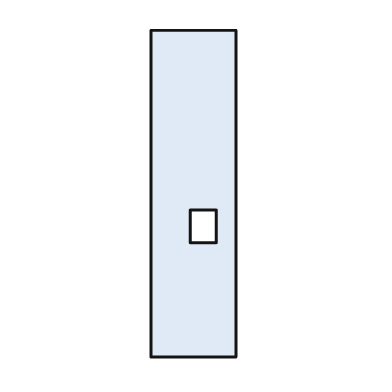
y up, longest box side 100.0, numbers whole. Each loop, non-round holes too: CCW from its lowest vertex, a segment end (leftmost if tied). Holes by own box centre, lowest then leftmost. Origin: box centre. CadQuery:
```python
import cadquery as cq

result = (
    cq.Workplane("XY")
    .moveTo(-13.0, -50.0)
    .lineTo(13.0, -50.0)
    .lineTo(13.0, 50.0)
    .lineTo(-13.0, 50.0)
    .close()
    .moveTo(-1.0, -15.0)
    .lineTo(7.0, -15.0)
    .lineTo(7.0, -5.0)
    .lineTo(-1.0, -5.0)
    .close()
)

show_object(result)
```